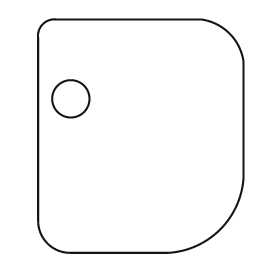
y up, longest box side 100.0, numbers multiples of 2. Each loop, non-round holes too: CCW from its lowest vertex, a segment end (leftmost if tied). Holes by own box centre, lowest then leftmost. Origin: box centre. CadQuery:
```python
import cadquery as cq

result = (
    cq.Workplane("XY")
    .moveTo(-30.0, -50.0)
    .lineTo(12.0, -50.0)
    .threePointArc((34.0, -40.0), (44.0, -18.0))
    .lineTo(44.0, 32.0)
    .threePointArc((38.0, 44.0), (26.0, 50.0))
    .lineTo(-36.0, 50.0)
    .threePointArc((-42.0, 48.0), (-44.0, 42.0))
    .lineTo(-44.0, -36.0)
    .threePointArc((-40.0, -46.0), (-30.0, -50.0))
    .close()
    .moveTo(-30.0, 16.0)
    .circle(8.0)
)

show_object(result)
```